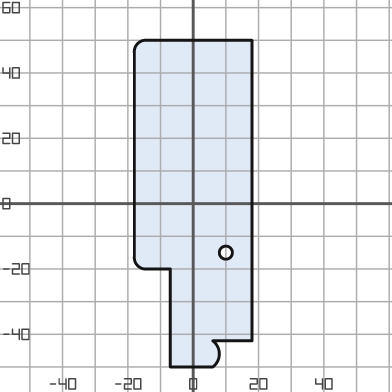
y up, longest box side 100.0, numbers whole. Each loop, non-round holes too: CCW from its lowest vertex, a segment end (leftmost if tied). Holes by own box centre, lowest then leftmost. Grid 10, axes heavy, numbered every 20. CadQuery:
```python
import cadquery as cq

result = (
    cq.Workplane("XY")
    .moveTo(-7.0, -50.0)
    .lineTo(6.0, -50.0)
    .threePointArc((8.0, -46.0), (6.0, -42.0))
    .lineTo(18.0, -42.0)
    .lineTo(18.0, 50.0)
    .lineTo(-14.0, 50.0)
    .threePointArc((-17.0, 49.0), (-18.0, 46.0))
    .lineTo(-18.0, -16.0)
    .threePointArc((-17.0, -19.0), (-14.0, -20.0))
    .lineTo(-7.0, -20.0)
    .close()
    .moveTo(10.0, -15.0)
    .circle(2.0)
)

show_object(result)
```